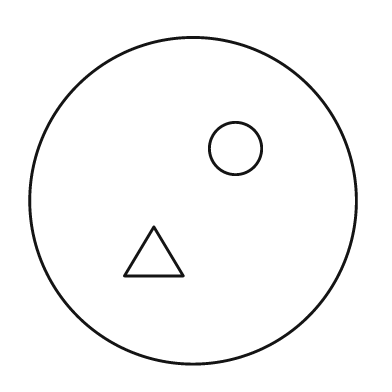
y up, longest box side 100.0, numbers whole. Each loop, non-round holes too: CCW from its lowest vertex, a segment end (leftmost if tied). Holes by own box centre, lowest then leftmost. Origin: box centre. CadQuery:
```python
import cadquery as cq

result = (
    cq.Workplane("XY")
    .moveTo(0.0, 0.0)
    .circle(50.0)
    .moveTo(-21.0, -23.0)
    .lineTo(-3.0, -23.0)
    .lineTo(-12.0, -8.0)
    .close()
    .moveTo(13.0, 16.0)
    .circle(8.0)
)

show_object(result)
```